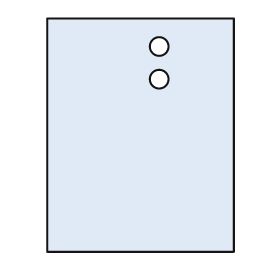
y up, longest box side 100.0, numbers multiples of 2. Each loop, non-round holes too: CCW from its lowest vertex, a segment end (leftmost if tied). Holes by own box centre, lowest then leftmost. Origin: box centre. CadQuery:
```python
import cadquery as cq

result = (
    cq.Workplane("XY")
    .moveTo(-40.0, -50.0)
    .lineTo(40.0, -50.0)
    .lineTo(40.0, 50.0)
    .lineTo(-40.0, 50.0)
    .close()
    .moveTo(8.0, 24.0)
    .circle(4.0)
    .moveTo(8.0, 38.0)
    .circle(4.0)
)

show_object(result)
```